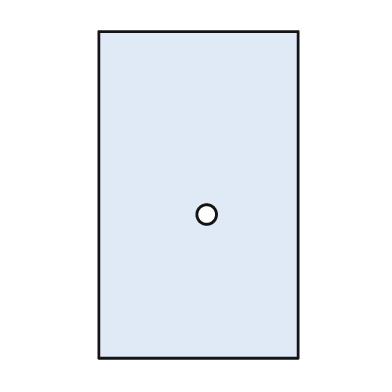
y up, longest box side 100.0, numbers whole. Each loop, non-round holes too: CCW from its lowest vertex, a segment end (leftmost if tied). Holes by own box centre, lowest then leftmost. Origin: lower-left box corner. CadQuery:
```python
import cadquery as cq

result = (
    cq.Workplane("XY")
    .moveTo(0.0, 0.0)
    .lineTo(61.0, 0.0)
    .lineTo(61.0, 100.0)
    .lineTo(0.0, 100.0)
    .close()
    .moveTo(33.0, 44.0)
    .circle(3.0)
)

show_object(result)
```